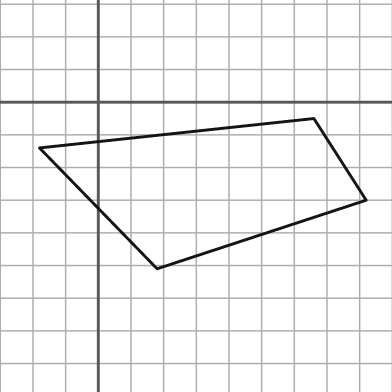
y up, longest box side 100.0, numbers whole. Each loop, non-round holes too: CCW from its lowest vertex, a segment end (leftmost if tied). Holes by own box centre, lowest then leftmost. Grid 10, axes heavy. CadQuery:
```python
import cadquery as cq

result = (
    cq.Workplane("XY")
    .moveTo(18.0, -51.0)
    .lineTo(82.0, -30.0)
    .lineTo(66.0, -5.0)
    .lineTo(-18.0, -14.0)
    .close()
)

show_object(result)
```